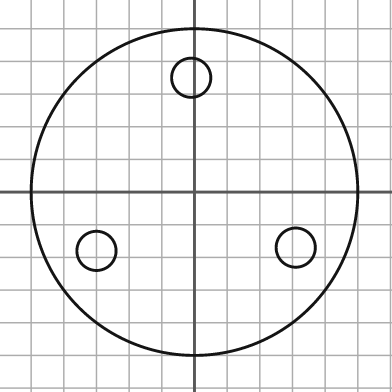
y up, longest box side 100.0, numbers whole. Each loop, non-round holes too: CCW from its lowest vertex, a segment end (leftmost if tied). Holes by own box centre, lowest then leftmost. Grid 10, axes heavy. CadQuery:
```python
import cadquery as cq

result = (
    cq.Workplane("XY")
    .moveTo(0.0, 0.0)
    .circle(50.0)
    .moveTo(-30.0, -18.0)
    .circle(6.0)
    .moveTo(31.0, -17.0)
    .circle(6.0)
    .moveTo(-1.0, 35.0)
    .circle(6.0)
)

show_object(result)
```